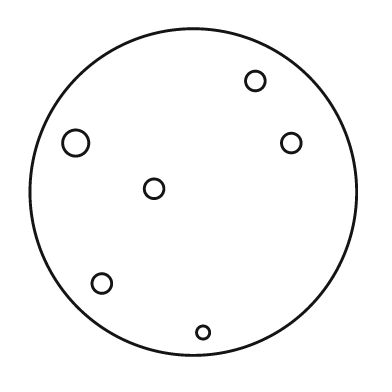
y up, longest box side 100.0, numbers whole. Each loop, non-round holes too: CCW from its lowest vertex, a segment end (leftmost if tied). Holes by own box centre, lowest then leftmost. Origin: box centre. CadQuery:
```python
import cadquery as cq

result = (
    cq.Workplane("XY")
    .moveTo(0.0, 0.0)
    .circle(50.0)
    .moveTo(3.0, -43.0)
    .circle(2.0)
    .moveTo(-28.0, -28.0)
    .circle(3.0)
    .moveTo(-12.0, 1.0)
    .circle(3.0)
    .moveTo(-36.0, 15.0)
    .circle(4.0)
    .moveTo(30.0, 15.0)
    .circle(3.0)
    .moveTo(19.0, 34.0)
    .circle(3.0)
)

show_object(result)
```